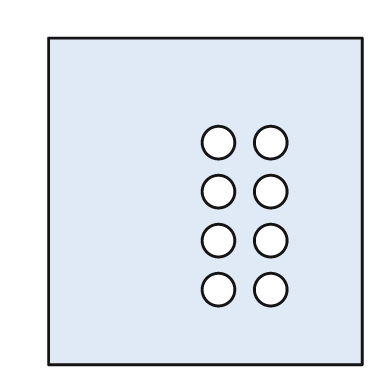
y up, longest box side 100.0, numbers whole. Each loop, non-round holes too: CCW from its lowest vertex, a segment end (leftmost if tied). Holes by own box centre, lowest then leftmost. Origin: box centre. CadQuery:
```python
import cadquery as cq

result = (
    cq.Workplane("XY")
    .moveTo(-48.0, -50.0)
    .lineTo(48.0, -50.0)
    .lineTo(48.0, 50.0)
    .lineTo(-48.0, 50.0)
    .close()
    .moveTo(4.0, -27.0)
    .circle(5.0)
    .moveTo(20.0, -27.0)
    .circle(5.0)
    .moveTo(4.0, -12.0)
    .circle(5.0)
    .moveTo(20.0, -12.0)
    .circle(5.0)
    .moveTo(4.0, 3.0)
    .circle(5.0)
    .moveTo(20.0, 3.0)
    .circle(5.0)
    .moveTo(4.0, 18.0)
    .circle(5.0)
    .moveTo(20.0, 18.0)
    .circle(5.0)
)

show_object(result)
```